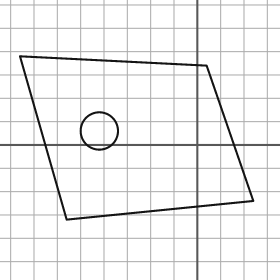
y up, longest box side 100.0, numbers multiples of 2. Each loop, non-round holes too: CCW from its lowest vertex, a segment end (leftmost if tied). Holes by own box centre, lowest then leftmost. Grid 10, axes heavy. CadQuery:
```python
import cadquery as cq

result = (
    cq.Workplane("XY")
    .moveTo(-56.0, -32.0)
    .lineTo(24.0, -24.0)
    .lineTo(4.0, 34.0)
    .lineTo(-76.0, 38.0)
    .close()
    .moveTo(-42.0, 6.0)
    .circle(8.0)
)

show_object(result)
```